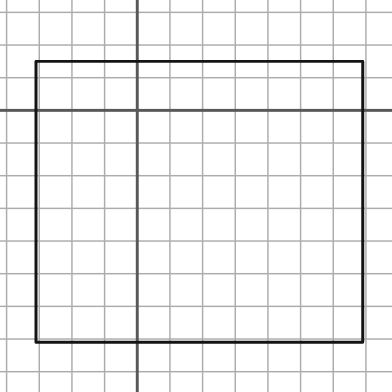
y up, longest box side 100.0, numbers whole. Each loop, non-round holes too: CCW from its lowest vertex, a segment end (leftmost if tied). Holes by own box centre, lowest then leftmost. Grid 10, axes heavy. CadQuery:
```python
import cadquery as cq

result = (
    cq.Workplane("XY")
    .moveTo(-31.0, -71.0)
    .lineTo(69.0, -71.0)
    .lineTo(69.0, 15.0)
    .lineTo(-31.0, 15.0)
    .close()
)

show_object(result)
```